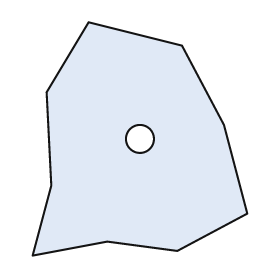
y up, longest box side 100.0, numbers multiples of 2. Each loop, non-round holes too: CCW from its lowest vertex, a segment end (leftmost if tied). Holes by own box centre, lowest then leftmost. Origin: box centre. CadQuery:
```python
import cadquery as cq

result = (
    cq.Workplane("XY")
    .moveTo(-46.0, -50.0)
    .lineTo(-14.0, -44.0)
    .lineTo(16.0, -48.0)
    .lineTo(46.0, -32.0)
    .lineTo(36.0, 6.0)
    .lineTo(18.0, 40.0)
    .lineTo(-22.0, 50.0)
    .lineTo(-40.0, 20.0)
    .lineTo(-38.0, -20.0)
    .close()
    .moveTo(0.0, 0.0)
    .circle(6.0)
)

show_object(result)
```